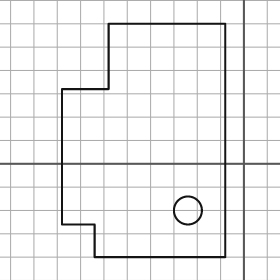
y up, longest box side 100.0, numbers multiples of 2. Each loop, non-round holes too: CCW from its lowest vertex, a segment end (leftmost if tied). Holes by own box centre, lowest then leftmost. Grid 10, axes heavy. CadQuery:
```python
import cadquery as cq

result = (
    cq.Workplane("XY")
    .moveTo(-64.0, -40.0)
    .lineTo(-8.0, -40.0)
    .lineTo(-8.0, 60.0)
    .lineTo(-58.0, 60.0)
    .lineTo(-58.0, 32.0)
    .lineTo(-78.0, 32.0)
    .lineTo(-78.0, -26.0)
    .lineTo(-64.0, -26.0)
    .close()
    .moveTo(-24.0, -20.0)
    .circle(6.0)
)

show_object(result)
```